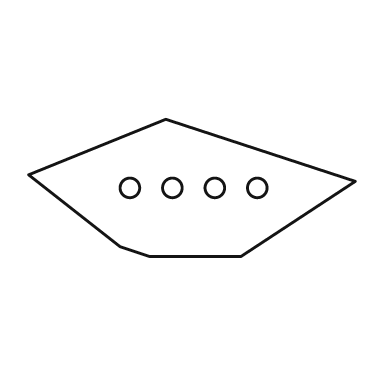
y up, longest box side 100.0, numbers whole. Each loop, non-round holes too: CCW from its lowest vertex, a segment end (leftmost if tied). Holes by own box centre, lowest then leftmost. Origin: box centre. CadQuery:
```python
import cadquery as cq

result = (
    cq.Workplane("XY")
    .moveTo(-13.0, -21.0)
    .lineTo(15.0, -21.0)
    .lineTo(50.0, 2.0)
    .lineTo(-8.0, 21.0)
    .lineTo(-50.0, 4.0)
    .lineTo(-22.0, -18.0)
    .close()
    .moveTo(-19.0, 0.0)
    .circle(3.0)
    .moveTo(-6.0, 0.0)
    .circle(3.0)
    .moveTo(7.0, 0.0)
    .circle(3.0)
    .moveTo(20.0, 0.0)
    .circle(3.0)
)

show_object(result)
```